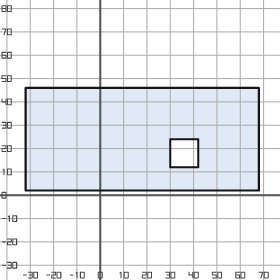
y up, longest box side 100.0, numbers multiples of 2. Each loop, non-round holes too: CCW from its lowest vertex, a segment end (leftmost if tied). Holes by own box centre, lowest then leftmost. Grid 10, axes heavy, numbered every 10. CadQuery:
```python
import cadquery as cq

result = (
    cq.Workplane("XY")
    .moveTo(-32.0, 2.0)
    .lineTo(68.0, 2.0)
    .lineTo(68.0, 46.0)
    .lineTo(-32.0, 46.0)
    .close()
    .moveTo(30.0, 12.0)
    .lineTo(42.0, 12.0)
    .lineTo(42.0, 24.0)
    .lineTo(30.0, 24.0)
    .close()
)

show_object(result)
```